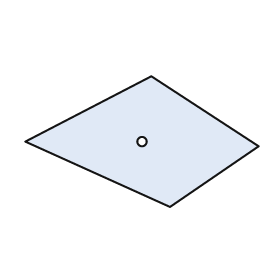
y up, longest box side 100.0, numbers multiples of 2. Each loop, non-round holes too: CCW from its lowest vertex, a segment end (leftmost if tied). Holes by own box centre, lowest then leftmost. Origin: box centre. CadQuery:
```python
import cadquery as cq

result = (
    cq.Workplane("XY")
    .moveTo(12.0, -28.0)
    .lineTo(50.0, -2.0)
    .lineTo(4.0, 28.0)
    .lineTo(-50.0, 0.0)
    .close()
    .moveTo(0.0, 0.0)
    .circle(2.0)
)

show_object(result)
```